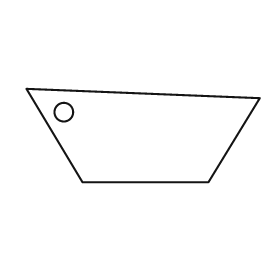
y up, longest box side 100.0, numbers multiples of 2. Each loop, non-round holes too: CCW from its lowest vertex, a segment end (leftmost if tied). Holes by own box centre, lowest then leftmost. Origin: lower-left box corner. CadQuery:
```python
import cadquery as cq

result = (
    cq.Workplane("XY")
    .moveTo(24.0, 0.0)
    .lineTo(78.0, 0.0)
    .lineTo(100.0, 36.0)
    .lineTo(0.0, 40.0)
    .close()
    .moveTo(16.0, 30.0)
    .circle(4.0)
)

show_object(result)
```